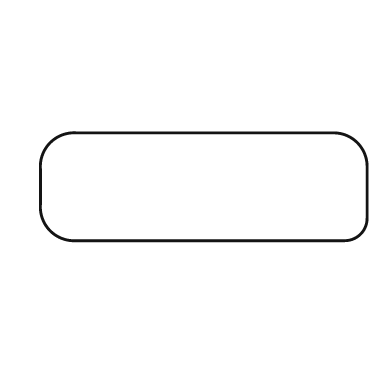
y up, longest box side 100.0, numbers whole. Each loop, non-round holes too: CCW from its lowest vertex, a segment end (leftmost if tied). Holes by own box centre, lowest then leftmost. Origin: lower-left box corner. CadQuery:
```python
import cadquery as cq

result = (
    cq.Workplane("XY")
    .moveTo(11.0, 0.0)
    .lineTo(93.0, 0.0)
    .threePointArc((98.0, 2.0), (100.0, 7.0))
    .lineTo(100.0, 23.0)
    .threePointArc((97.0, 30.0), (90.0, 33.0))
    .lineTo(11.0, 33.0)
    .threePointArc((3.0, 30.0), (0.0, 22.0))
    .lineTo(0.0, 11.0)
    .threePointArc((3.0, 3.0), (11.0, 0.0))
    .close()
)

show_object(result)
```